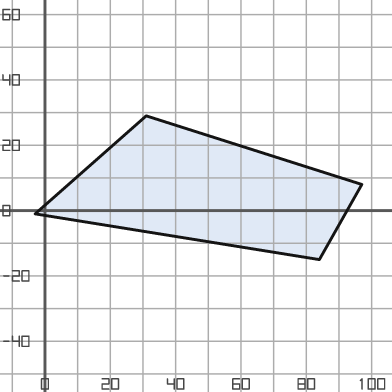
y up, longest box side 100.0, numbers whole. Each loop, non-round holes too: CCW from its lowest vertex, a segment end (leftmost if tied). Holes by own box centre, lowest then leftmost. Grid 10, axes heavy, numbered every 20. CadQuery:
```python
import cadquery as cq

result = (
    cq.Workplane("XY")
    .moveTo(84.0, -15.0)
    .lineTo(97.0, 8.0)
    .lineTo(31.0, 29.0)
    .lineTo(-3.0, -1.0)
    .close()
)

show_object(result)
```